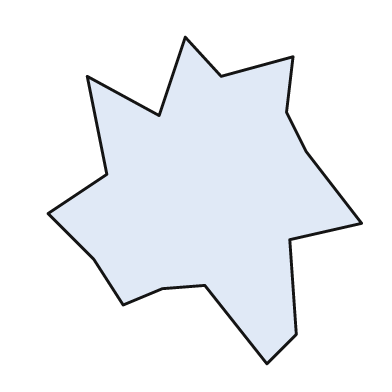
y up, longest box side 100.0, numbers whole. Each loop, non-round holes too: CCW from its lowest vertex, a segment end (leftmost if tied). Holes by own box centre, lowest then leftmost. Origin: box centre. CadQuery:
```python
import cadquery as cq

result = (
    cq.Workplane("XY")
    .moveTo(19.0, -50.0)
    .lineTo(28.0, -41.0)
    .lineTo(26.0, -12.0)
    .lineTo(48.0, -7.0)
    .lineTo(31.0, 15.0)
    .lineTo(25.0, 27.0)
    .lineTo(27.0, 44.0)
    .lineTo(5.0, 38.0)
    .lineTo(-6.0, 50.0)
    .lineTo(-14.0, 26.0)
    .lineTo(-36.0, 38.0)
    .lineTo(-30.0, 8.0)
    .lineTo(-48.0, -4.0)
    .lineTo(-34.0, -18.0)
    .lineTo(-25.0, -32.0)
    .lineTo(-13.0, -27.0)
    .lineTo(0.0, -26.0)
    .close()
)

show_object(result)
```